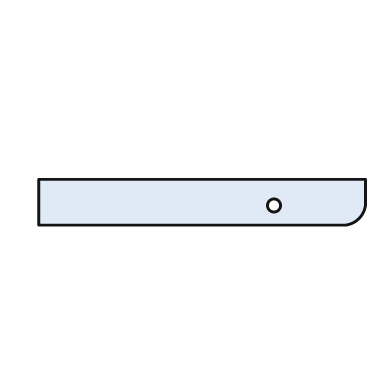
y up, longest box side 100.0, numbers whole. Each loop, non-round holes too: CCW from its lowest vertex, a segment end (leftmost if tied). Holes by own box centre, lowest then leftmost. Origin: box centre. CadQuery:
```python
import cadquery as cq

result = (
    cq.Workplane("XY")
    .moveTo(-50.0, -7.0)
    .lineTo(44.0, -7.0)
    .threePointArc((48.0, -5.0), (50.0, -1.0))
    .lineTo(50.0, 7.0)
    .lineTo(-50.0, 7.0)
    .close()
    .moveTo(22.0, -1.0)
    .circle(2.0)
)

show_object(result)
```